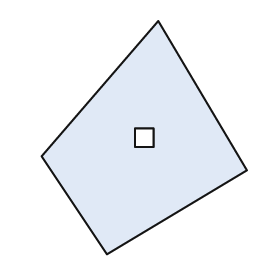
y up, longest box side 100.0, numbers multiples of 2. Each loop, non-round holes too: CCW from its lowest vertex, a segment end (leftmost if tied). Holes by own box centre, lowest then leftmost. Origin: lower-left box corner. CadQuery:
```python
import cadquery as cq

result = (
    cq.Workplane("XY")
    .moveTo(28.0, 0.0)
    .lineTo(88.0, 36.0)
    .lineTo(50.0, 100.0)
    .lineTo(0.0, 42.0)
    .close()
    .moveTo(40.0, 46.0)
    .lineTo(48.0, 46.0)
    .lineTo(48.0, 54.0)
    .lineTo(40.0, 54.0)
    .close()
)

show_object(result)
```